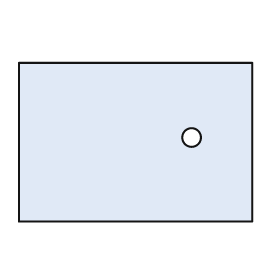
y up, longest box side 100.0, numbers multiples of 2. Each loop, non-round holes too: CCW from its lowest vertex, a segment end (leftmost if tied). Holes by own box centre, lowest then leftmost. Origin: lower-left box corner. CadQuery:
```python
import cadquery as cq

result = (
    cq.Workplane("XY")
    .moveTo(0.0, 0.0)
    .lineTo(100.0, 0.0)
    .lineTo(100.0, 68.0)
    .lineTo(0.0, 68.0)
    .close()
    .moveTo(74.0, 36.0)
    .circle(4.0)
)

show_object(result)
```